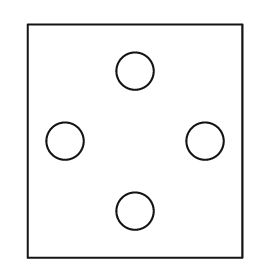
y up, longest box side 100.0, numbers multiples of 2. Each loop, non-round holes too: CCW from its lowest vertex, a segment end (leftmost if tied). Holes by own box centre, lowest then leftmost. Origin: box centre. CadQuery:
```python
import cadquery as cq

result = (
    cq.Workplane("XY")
    .moveTo(-46.0, -50.0)
    .lineTo(46.0, -50.0)
    .lineTo(46.0, 50.0)
    .lineTo(-46.0, 50.0)
    .close()
    .moveTo(0.0, -30.0)
    .circle(8.0)
    .moveTo(-30.0, 0.0)
    .circle(8.0)
    .moveTo(30.0, 0.0)
    .circle(8.0)
    .moveTo(0.0, 30.0)
    .circle(8.0)
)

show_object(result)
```